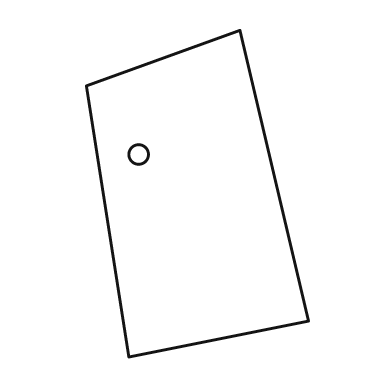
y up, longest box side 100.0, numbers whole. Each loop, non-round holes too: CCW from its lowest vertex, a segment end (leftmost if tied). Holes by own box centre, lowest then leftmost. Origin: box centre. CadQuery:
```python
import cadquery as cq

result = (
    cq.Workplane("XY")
    .moveTo(-21.0, -50.0)
    .lineTo(34.0, -39.0)
    .lineTo(13.0, 50.0)
    .lineTo(-34.0, 33.0)
    .close()
    .moveTo(-18.0, 12.0)
    .circle(3.0)
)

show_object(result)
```